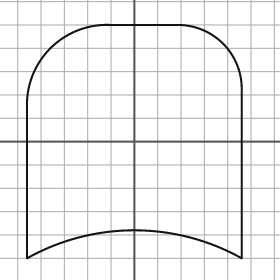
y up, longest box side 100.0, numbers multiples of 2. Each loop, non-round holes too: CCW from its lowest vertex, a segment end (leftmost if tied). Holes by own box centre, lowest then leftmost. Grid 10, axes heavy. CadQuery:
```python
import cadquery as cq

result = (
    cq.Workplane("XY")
    .moveTo(-46.0, -50.0)
    .threePointArc((0.0, -38.0), (46.0, -50.0))
    .lineTo(46.0, 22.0)
    .threePointArc((38.0, 42.0), (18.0, 50.0))
    .lineTo(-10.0, 50.0)
    .threePointArc((-36.0, 40.0), (-46.0, 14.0))
    .close()
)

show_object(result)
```